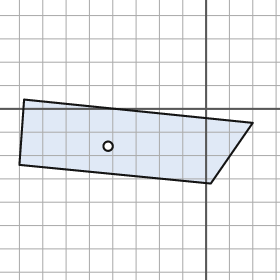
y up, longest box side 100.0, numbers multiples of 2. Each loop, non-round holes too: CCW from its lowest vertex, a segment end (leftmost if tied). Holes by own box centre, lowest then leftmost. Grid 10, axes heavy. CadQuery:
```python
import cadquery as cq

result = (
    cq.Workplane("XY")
    .moveTo(2.0, -32.0)
    .lineTo(20.0, -6.0)
    .lineTo(-78.0, 4.0)
    .lineTo(-80.0, -24.0)
    .close()
    .moveTo(-42.0, -16.0)
    .circle(2.0)
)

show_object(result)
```